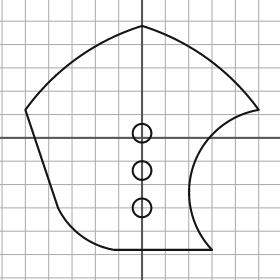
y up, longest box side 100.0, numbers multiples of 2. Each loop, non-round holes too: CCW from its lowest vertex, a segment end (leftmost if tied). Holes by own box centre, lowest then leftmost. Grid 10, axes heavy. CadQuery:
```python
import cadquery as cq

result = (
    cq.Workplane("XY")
    .moveTo(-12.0, -48.0)
    .lineTo(30.0, -48.0)
    .threePointArc((22.0, -12.0), (50.0, 12.0))
    .threePointArc((28.0, 34.0), (0.0, 48.0))
    .threePointArc((-28.0, 34.0), (-50.0, 12.0))
    .lineTo(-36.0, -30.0)
    .threePointArc((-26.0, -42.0), (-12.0, -48.0))
    .close()
    .moveTo(0.0, -30.0)
    .circle(4.0)
    .moveTo(0.0, -14.0)
    .circle(4.0)
    .moveTo(0.0, 2.0)
    .circle(4.0)
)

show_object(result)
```